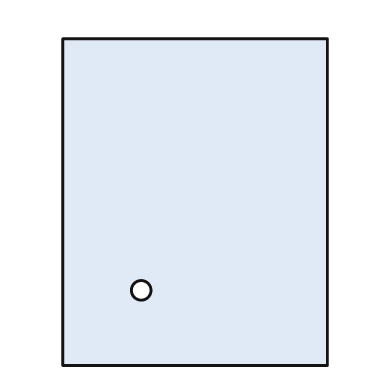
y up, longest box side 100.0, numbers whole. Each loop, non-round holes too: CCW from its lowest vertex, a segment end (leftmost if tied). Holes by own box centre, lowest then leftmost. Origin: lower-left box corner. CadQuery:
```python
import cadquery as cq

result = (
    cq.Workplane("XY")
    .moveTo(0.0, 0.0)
    .lineTo(81.0, 0.0)
    .lineTo(81.0, 100.0)
    .lineTo(0.0, 100.0)
    .close()
    .moveTo(24.0, 23.0)
    .circle(3.0)
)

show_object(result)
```